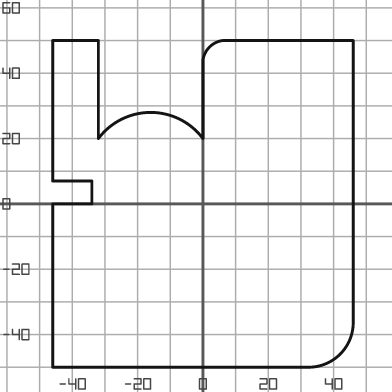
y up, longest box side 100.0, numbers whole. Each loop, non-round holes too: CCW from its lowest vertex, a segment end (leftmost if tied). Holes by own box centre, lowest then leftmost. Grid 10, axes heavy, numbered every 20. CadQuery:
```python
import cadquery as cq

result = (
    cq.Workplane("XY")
    .moveTo(-46.0, -50.0)
    .lineTo(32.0, -50.0)
    .threePointArc((42.0, -46.0), (46.0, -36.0))
    .lineTo(46.0, 50.0)
    .lineTo(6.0, 50.0)
    .threePointArc((2.0, 48.0), (0.0, 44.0))
    .lineTo(0.0, 20.0)
    .threePointArc((-16.0, 28.0), (-32.0, 20.0))
    .lineTo(-32.0, 50.0)
    .lineTo(-46.0, 50.0)
    .lineTo(-46.0, 7.0)
    .lineTo(-34.0, 7.0)
    .lineTo(-34.0, 0.0)
    .lineTo(-46.0, 0.0)
    .close()
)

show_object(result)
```